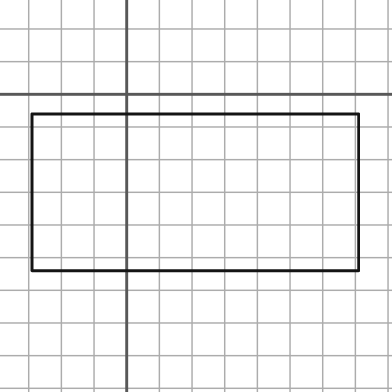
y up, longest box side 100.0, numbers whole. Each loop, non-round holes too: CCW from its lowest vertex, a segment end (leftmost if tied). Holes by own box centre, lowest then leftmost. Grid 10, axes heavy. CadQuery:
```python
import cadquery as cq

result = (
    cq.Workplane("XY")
    .moveTo(-29.0, -54.0)
    .lineTo(71.0, -54.0)
    .lineTo(71.0, -6.0)
    .lineTo(-29.0, -6.0)
    .close()
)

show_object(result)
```